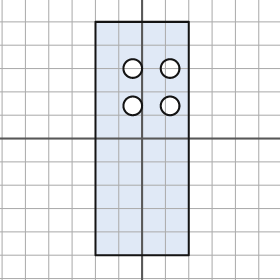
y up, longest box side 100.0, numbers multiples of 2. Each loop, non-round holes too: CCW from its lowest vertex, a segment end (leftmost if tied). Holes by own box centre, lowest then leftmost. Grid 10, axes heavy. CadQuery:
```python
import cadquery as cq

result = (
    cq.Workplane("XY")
    .moveTo(-20.0, -50.0)
    .lineTo(20.0, -50.0)
    .lineTo(20.0, 50.0)
    .lineTo(-20.0, 50.0)
    .close()
    .moveTo(-4.0, 14.0)
    .circle(4.0)
    .moveTo(12.0, 14.0)
    .circle(4.0)
    .moveTo(-4.0, 30.0)
    .circle(4.0)
    .moveTo(12.0, 30.0)
    .circle(4.0)
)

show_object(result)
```